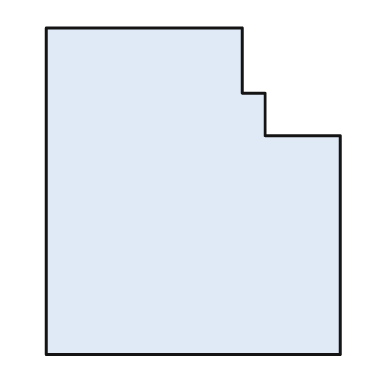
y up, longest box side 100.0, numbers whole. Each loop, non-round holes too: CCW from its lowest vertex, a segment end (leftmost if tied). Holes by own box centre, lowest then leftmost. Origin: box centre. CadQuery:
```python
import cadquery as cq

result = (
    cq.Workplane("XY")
    .moveTo(-45.0, -50.0)
    .lineTo(45.0, -50.0)
    .lineTo(45.0, 17.0)
    .lineTo(22.0, 17.0)
    .lineTo(22.0, 30.0)
    .lineTo(15.0, 30.0)
    .lineTo(15.0, 50.0)
    .lineTo(-45.0, 50.0)
    .close()
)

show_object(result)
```